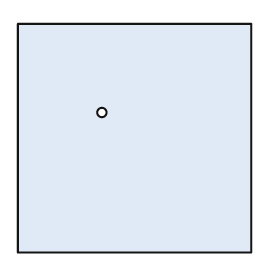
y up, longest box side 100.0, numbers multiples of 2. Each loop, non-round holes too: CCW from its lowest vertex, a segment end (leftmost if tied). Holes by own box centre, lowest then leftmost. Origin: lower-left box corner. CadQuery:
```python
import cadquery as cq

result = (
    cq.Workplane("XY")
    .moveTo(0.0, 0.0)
    .lineTo(100.0, 0.0)
    .lineTo(100.0, 98.0)
    .lineTo(0.0, 98.0)
    .close()
    .moveTo(36.0, 60.0)
    .circle(2.0)
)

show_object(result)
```